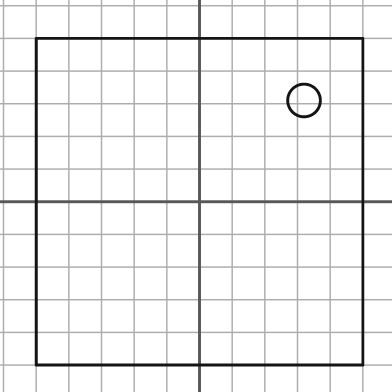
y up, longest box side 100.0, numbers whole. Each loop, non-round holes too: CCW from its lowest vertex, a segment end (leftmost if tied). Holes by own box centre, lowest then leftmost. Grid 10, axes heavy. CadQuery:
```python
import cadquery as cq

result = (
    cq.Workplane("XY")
    .moveTo(-50.0, -50.0)
    .lineTo(50.0, -50.0)
    .lineTo(50.0, 50.0)
    .lineTo(-50.0, 50.0)
    .close()
    .moveTo(32.0, 31.0)
    .circle(5.0)
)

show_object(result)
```